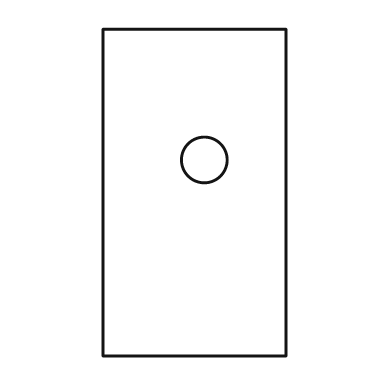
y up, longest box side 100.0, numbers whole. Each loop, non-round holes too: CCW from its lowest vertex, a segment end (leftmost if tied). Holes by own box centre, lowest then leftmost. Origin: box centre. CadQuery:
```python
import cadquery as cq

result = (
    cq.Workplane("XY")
    .moveTo(-28.0, -50.0)
    .lineTo(28.0, -50.0)
    .lineTo(28.0, 50.0)
    .lineTo(-28.0, 50.0)
    .close()
    .moveTo(3.0, 10.0)
    .circle(7.0)
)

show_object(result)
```